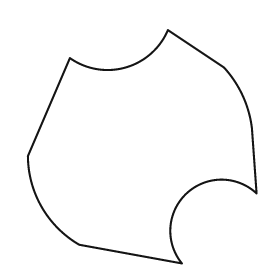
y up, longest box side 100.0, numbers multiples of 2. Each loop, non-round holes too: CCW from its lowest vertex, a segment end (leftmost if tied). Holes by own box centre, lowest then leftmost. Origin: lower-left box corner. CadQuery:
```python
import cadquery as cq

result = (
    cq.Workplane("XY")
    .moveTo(66.0, 0.0)
    .threePointArc((68.0, 30.0), (98.0, 30.0))
    .lineTo(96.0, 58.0)
    .threePointArc((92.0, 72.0), (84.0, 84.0))
    .lineTo(60.0, 100.0)
    .threePointArc((42.0, 84.0), (18.0, 88.0))
    .lineTo(0.0, 46.0)
    .threePointArc((6.0, 24.0), (22.0, 8.0))
    .close()
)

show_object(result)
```